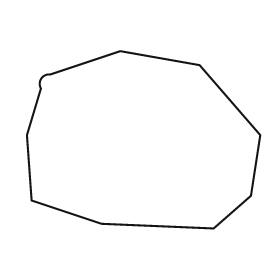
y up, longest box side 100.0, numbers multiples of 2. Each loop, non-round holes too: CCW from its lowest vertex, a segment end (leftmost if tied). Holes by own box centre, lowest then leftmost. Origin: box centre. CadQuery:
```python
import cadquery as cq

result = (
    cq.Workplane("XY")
    .moveTo(30.0, -38.0)
    .lineTo(46.0, -24.0)
    .lineTo(50.0, 2.0)
    .lineTo(24.0, 32.0)
    .lineTo(-10.0, 38.0)
    .lineTo(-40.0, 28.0)
    .threePointArc((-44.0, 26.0), (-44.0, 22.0))
    .lineTo(-50.0, 2.0)
    .lineTo(-48.0, -26.0)
    .lineTo(-18.0, -36.0)
    .close()
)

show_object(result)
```